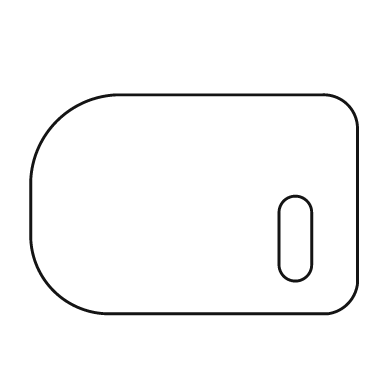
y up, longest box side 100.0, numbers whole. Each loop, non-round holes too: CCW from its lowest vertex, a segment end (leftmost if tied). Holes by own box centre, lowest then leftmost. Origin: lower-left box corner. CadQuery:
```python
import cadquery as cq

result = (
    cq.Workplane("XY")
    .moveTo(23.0, 0.0)
    .lineTo(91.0, 0.0)
    .threePointArc((97.0, 3.0), (100.0, 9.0))
    .lineTo(100.0, 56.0)
    .threePointArc((97.0, 64.0), (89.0, 67.0))
    .lineTo(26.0, 67.0)
    .threePointArc((8.0, 59.0), (0.0, 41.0))
    .lineTo(0.0, 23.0)
    .threePointArc((7.0, 7.0), (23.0, 0.0))
    .close()
    .moveTo(76.0, 15.0)
    .threePointArc((81.0, 10.0), (86.0, 15.0))
    .lineTo(86.0, 31.0)
    .threePointArc((81.0, 36.0), (76.0, 31.0))
    .close()
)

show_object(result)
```